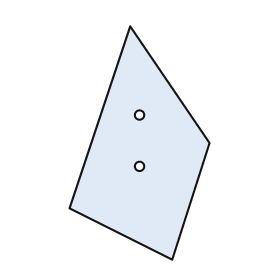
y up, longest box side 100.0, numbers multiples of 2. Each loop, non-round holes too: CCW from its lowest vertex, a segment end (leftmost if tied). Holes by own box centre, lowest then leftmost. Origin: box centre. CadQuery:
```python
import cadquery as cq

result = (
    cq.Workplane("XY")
    .moveTo(14.0, -50.0)
    .lineTo(30.0, 0.0)
    .lineTo(-4.0, 50.0)
    .lineTo(-30.0, -28.0)
    .close()
    .moveTo(0.0, -10.0)
    .circle(2.0)
    .moveTo(0.0, 12.0)
    .circle(2.0)
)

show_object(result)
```